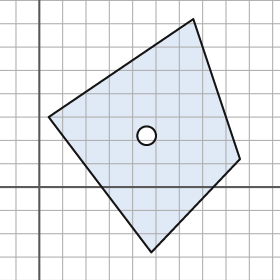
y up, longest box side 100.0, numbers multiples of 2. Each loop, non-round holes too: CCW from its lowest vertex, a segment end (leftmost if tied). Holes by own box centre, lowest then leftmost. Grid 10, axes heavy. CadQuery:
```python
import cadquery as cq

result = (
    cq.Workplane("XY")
    .moveTo(48.0, -28.0)
    .lineTo(86.0, 12.0)
    .lineTo(66.0, 72.0)
    .lineTo(4.0, 30.0)
    .close()
    .moveTo(46.0, 22.0)
    .circle(4.0)
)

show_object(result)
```